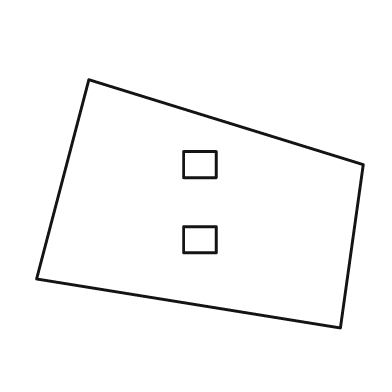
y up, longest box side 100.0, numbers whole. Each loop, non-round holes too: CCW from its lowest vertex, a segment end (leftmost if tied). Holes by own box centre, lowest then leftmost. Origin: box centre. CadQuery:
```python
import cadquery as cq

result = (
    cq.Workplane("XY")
    .moveTo(43.0, -38.0)
    .lineTo(50.0, 12.0)
    .lineTo(-34.0, 38.0)
    .lineTo(-50.0, -23.0)
    .close()
    .moveTo(-5.0, -15.0)
    .lineTo(5.0, -15.0)
    .lineTo(5.0, -7.0)
    .lineTo(-5.0, -7.0)
    .close()
    .moveTo(-5.0, 8.0)
    .lineTo(5.0, 8.0)
    .lineTo(5.0, 16.0)
    .lineTo(-5.0, 16.0)
    .close()
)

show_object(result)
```